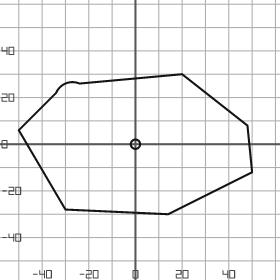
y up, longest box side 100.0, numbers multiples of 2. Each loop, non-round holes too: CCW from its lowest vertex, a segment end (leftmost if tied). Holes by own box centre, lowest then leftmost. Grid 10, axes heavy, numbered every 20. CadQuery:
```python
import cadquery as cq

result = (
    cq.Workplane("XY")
    .moveTo(14.0, -30.0)
    .lineTo(50.0, -12.0)
    .lineTo(48.0, 8.0)
    .lineTo(20.0, 30.0)
    .lineTo(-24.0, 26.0)
    .threePointArc((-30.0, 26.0), (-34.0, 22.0))
    .lineTo(-50.0, 6.0)
    .lineTo(-30.0, -28.0)
    .close()
    .moveTo(0.0, 0.0)
    .circle(2.0)
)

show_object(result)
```